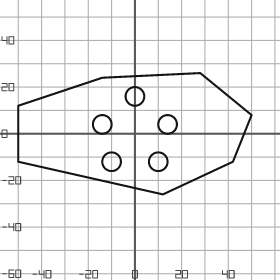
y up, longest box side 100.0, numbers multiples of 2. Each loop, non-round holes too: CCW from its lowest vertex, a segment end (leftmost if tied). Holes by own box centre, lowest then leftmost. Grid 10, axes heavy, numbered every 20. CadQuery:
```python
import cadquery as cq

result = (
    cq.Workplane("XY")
    .moveTo(12.0, -26.0)
    .lineTo(42.0, -12.0)
    .lineTo(50.0, 8.0)
    .lineTo(28.0, 26.0)
    .lineTo(-14.0, 24.0)
    .lineTo(-50.0, 12.0)
    .lineTo(-50.0, -12.0)
    .close()
    .moveTo(-10.0, -12.0)
    .circle(4.0)
    .moveTo(10.0, -12.0)
    .circle(4.0)
    .moveTo(-14.0, 4.0)
    .circle(4.0)
    .moveTo(14.0, 4.0)
    .circle(4.0)
    .moveTo(0.0, 16.0)
    .circle(4.0)
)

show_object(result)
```